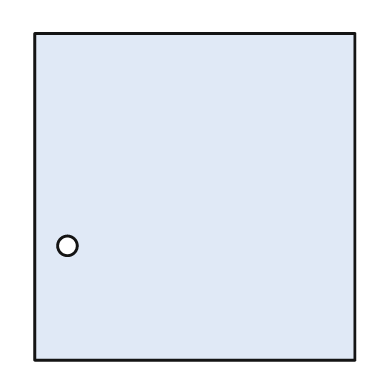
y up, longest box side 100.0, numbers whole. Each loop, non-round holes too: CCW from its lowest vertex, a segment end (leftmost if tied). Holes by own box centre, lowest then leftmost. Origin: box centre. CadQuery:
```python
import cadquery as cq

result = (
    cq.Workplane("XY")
    .moveTo(-49.0, -50.0)
    .lineTo(49.0, -50.0)
    .lineTo(49.0, 50.0)
    .lineTo(-49.0, 50.0)
    .close()
    .moveTo(-39.0, -15.0)
    .circle(3.0)
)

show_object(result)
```